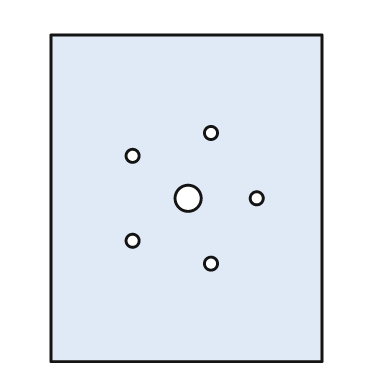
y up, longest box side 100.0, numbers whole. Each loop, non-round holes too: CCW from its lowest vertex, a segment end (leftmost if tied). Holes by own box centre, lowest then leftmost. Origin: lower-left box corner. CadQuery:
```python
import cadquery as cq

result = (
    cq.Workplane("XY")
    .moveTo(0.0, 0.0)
    .lineTo(83.0, 0.0)
    .lineTo(83.0, 100.0)
    .lineTo(0.0, 100.0)
    .close()
    .moveTo(49.0, 30.0)
    .circle(2.0)
    .moveTo(25.0, 37.0)
    .circle(2.0)
    .moveTo(42.0, 50.0)
    .circle(4.0)
    .moveTo(63.0, 50.0)
    .circle(2.0)
    .moveTo(25.0, 63.0)
    .circle(2.0)
    .moveTo(49.0, 70.0)
    .circle(2.0)
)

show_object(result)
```